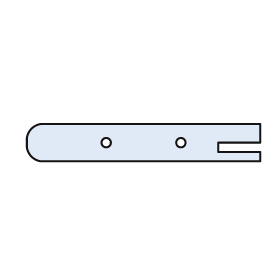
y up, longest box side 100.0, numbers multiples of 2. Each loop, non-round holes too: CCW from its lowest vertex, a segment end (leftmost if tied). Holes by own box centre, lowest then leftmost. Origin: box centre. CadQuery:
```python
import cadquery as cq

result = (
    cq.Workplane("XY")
    .moveTo(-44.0, -8.0)
    .lineTo(50.0, -8.0)
    .lineTo(50.0, -4.0)
    .lineTo(32.0, -4.0)
    .lineTo(32.0, 0.0)
    .lineTo(50.0, 0.0)
    .lineTo(50.0, 8.0)
    .lineTo(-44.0, 8.0)
    .threePointArc((-48.0, 6.0), (-50.0, 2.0))
    .lineTo(-50.0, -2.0)
    .threePointArc((-48.0, -6.0), (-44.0, -8.0))
    .close()
    .moveTo(-16.0, 0.0)
    .circle(2.0)
    .moveTo(16.0, 0.0)
    .circle(2.0)
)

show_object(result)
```